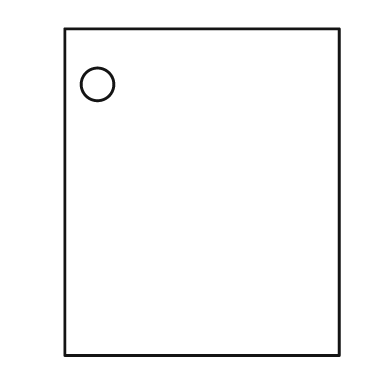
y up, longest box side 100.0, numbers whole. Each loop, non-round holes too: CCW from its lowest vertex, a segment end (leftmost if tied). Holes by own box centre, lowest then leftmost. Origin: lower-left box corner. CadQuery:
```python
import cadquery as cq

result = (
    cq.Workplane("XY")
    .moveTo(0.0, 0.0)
    .lineTo(84.0, 0.0)
    .lineTo(84.0, 100.0)
    .lineTo(0.0, 100.0)
    .close()
    .moveTo(10.0, 83.0)
    .circle(5.0)
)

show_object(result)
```